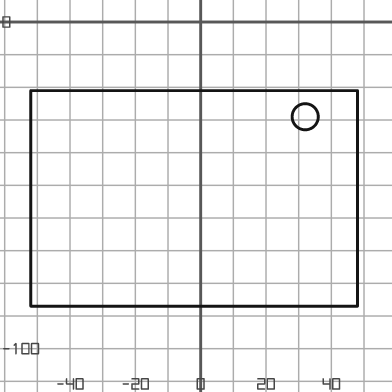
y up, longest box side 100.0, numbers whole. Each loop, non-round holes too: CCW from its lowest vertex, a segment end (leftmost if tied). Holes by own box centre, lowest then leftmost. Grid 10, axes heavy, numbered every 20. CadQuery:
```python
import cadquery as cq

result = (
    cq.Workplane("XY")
    .moveTo(-52.0, -87.0)
    .lineTo(48.0, -87.0)
    .lineTo(48.0, -21.0)
    .lineTo(-52.0, -21.0)
    .close()
    .moveTo(32.0, -29.0)
    .circle(4.0)
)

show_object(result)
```